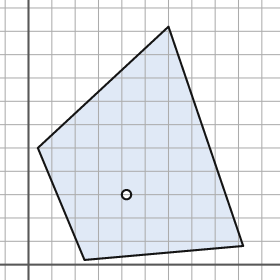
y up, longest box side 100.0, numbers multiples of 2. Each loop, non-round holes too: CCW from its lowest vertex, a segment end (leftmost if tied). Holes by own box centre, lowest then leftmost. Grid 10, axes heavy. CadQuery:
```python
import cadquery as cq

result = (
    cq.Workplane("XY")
    .moveTo(24.0, 2.0)
    .lineTo(92.0, 8.0)
    .lineTo(60.0, 102.0)
    .lineTo(4.0, 50.0)
    .close()
    .moveTo(42.0, 30.0)
    .circle(2.0)
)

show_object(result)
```